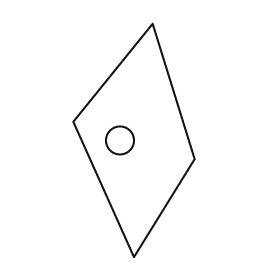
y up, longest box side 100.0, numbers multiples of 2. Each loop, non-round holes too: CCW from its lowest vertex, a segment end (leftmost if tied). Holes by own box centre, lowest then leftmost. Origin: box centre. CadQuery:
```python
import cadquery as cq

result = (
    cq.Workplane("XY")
    .moveTo(0.0, -50.0)
    .lineTo(26.0, -8.0)
    .lineTo(8.0, 50.0)
    .lineTo(-26.0, 8.0)
    .close()
    .moveTo(-6.0, 0.0)
    .circle(6.0)
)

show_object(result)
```